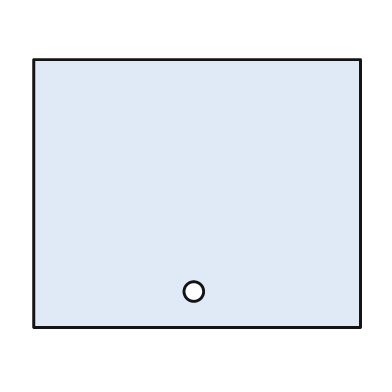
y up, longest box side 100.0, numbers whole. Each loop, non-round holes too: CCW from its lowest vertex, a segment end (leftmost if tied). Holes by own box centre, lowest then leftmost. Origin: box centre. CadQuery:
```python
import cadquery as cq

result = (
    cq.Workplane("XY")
    .moveTo(-50.0, -41.0)
    .lineTo(50.0, -41.0)
    .lineTo(50.0, 41.0)
    .lineTo(-50.0, 41.0)
    .close()
    .moveTo(-1.0, -30.0)
    .circle(3.0)
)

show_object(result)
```